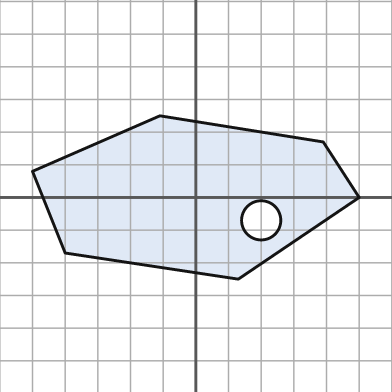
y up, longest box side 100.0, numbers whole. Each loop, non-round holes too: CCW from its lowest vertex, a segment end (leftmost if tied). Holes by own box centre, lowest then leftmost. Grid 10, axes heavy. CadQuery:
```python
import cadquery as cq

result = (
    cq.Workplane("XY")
    .moveTo(13.0, -25.0)
    .lineTo(50.0, 0.0)
    .lineTo(39.0, 17.0)
    .lineTo(-11.0, 25.0)
    .lineTo(-50.0, 8.0)
    .lineTo(-40.0, -17.0)
    .close()
    .moveTo(20.0, -7.0)
    .circle(6.0)
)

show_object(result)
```